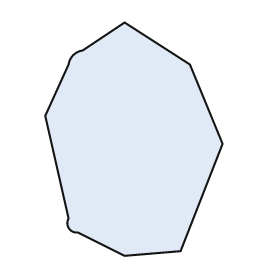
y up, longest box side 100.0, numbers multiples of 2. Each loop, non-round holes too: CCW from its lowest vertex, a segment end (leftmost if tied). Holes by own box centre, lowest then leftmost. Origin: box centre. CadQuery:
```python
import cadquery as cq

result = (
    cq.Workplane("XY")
    .moveTo(-4.0, -50.0)
    .lineTo(20.0, -48.0)
    .lineTo(38.0, -2.0)
    .lineTo(24.0, 32.0)
    .lineTo(-4.0, 50.0)
    .lineTo(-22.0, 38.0)
    .threePointArc((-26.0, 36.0), (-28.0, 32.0))
    .lineTo(-38.0, 10.0)
    .lineTo(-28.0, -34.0)
    .threePointArc((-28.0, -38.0), (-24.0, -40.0))
    .close()
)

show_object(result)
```